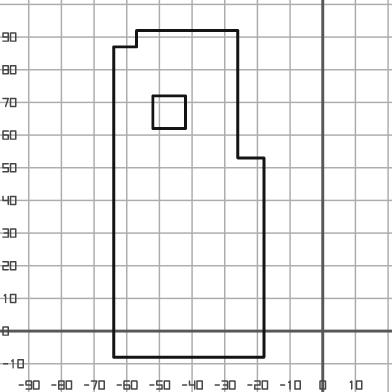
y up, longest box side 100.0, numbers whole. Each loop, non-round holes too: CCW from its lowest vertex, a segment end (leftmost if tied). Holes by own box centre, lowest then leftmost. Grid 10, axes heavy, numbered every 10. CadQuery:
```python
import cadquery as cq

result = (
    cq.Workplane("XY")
    .moveTo(-64.0, -8.0)
    .lineTo(-18.0, -8.0)
    .lineTo(-18.0, 53.0)
    .lineTo(-26.0, 53.0)
    .lineTo(-26.0, 92.0)
    .lineTo(-57.0, 92.0)
    .lineTo(-57.0, 87.0)
    .lineTo(-64.0, 87.0)
    .close()
    .moveTo(-52.0, 62.0)
    .lineTo(-42.0, 62.0)
    .lineTo(-42.0, 72.0)
    .lineTo(-52.0, 72.0)
    .close()
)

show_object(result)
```